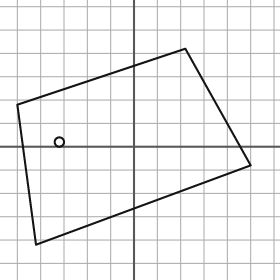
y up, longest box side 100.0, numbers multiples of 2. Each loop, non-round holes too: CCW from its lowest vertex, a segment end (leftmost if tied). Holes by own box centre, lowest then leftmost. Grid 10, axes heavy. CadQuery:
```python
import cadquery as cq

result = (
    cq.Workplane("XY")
    .moveTo(-42.0, -42.0)
    .lineTo(50.0, -8.0)
    .lineTo(22.0, 42.0)
    .lineTo(-50.0, 18.0)
    .close()
    .moveTo(-32.0, 2.0)
    .circle(2.0)
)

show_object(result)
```